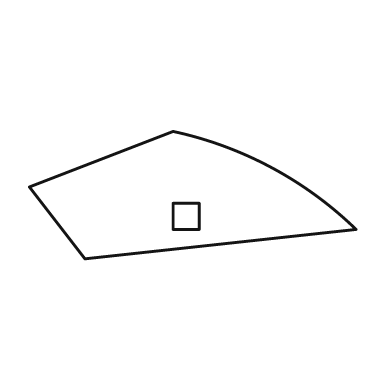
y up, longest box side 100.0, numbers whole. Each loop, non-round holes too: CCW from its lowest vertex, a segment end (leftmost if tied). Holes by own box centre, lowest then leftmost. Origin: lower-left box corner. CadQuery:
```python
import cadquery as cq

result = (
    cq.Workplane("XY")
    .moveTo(17.0, 0.0)
    .lineTo(100.0, 9.0)
    .threePointArc((74.0, 28.0), (44.0, 39.0))
    .lineTo(0.0, 22.0)
    .close()
    .moveTo(44.0, 9.0)
    .lineTo(52.0, 9.0)
    .lineTo(52.0, 17.0)
    .lineTo(44.0, 17.0)
    .close()
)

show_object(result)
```